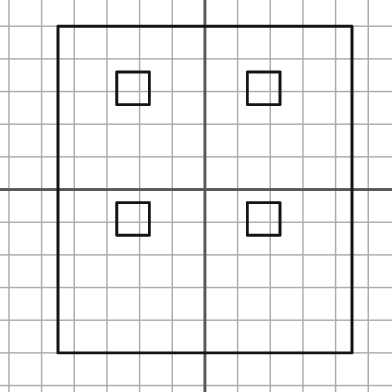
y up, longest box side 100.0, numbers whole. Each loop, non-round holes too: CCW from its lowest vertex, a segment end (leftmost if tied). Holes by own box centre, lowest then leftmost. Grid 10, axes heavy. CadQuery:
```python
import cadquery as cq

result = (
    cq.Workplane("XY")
    .moveTo(-45.0, -50.0)
    .lineTo(45.0, -50.0)
    .lineTo(45.0, 50.0)
    .lineTo(-45.0, 50.0)
    .close()
    .moveTo(-27.0, -14.0)
    .lineTo(-17.0, -14.0)
    .lineTo(-17.0, -4.0)
    .lineTo(-27.0, -4.0)
    .close()
    .moveTo(13.0, -14.0)
    .lineTo(23.0, -14.0)
    .lineTo(23.0, -4.0)
    .lineTo(13.0, -4.0)
    .close()
    .moveTo(-27.0, 26.0)
    .lineTo(-17.0, 26.0)
    .lineTo(-17.0, 36.0)
    .lineTo(-27.0, 36.0)
    .close()
    .moveTo(13.0, 26.0)
    .lineTo(23.0, 26.0)
    .lineTo(23.0, 36.0)
    .lineTo(13.0, 36.0)
    .close()
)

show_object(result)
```